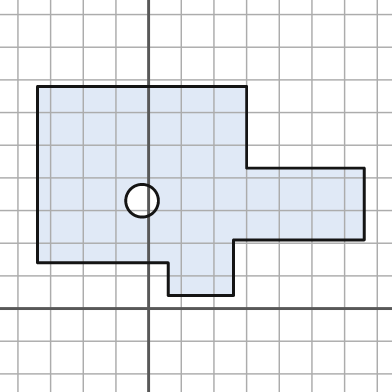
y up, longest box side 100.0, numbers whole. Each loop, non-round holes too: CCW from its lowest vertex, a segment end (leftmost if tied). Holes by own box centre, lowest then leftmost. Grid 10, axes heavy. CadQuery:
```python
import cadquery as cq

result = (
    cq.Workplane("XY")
    .moveTo(6.0, 4.0)
    .lineTo(26.0, 4.0)
    .lineTo(26.0, 21.0)
    .lineTo(66.0, 21.0)
    .lineTo(66.0, 43.0)
    .lineTo(30.0, 43.0)
    .lineTo(30.0, 68.0)
    .lineTo(-34.0, 68.0)
    .lineTo(-34.0, 14.0)
    .lineTo(6.0, 14.0)
    .close()
    .moveTo(-2.0, 33.0)
    .circle(5.0)
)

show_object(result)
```